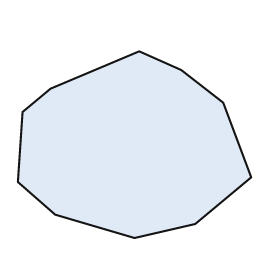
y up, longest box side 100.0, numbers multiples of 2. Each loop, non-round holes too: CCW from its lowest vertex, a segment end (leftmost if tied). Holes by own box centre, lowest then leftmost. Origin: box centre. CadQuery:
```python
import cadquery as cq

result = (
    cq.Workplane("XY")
    .moveTo(0.0, -40.0)
    .lineTo(26.0, -34.0)
    .lineTo(50.0, -14.0)
    .lineTo(38.0, 18.0)
    .lineTo(20.0, 32.0)
    .lineTo(2.0, 40.0)
    .lineTo(-36.0, 24.0)
    .lineTo(-48.0, 14.0)
    .lineTo(-50.0, -16.0)
    .lineTo(-34.0, -30.0)
    .close()
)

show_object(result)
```